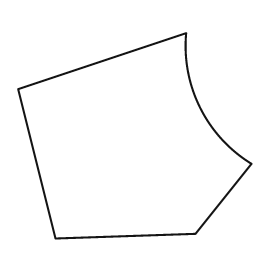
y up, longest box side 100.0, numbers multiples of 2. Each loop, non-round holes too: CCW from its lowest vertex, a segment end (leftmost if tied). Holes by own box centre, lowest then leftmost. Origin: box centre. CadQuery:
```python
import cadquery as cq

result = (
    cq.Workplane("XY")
    .moveTo(-34.0, -44.0)
    .lineTo(26.0, -42.0)
    .lineTo(50.0, -12.0)
    .threePointArc((28.0, 12.0), (22.0, 44.0))
    .lineTo(-50.0, 20.0)
    .close()
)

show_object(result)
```